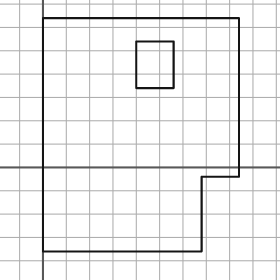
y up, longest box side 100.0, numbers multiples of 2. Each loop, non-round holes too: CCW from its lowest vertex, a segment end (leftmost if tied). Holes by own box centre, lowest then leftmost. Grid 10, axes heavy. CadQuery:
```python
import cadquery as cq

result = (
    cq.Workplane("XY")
    .moveTo(0.0, -36.0)
    .lineTo(68.0, -36.0)
    .lineTo(68.0, -4.0)
    .lineTo(84.0, -4.0)
    .lineTo(84.0, 64.0)
    .lineTo(0.0, 64.0)
    .close()
    .moveTo(40.0, 34.0)
    .lineTo(56.0, 34.0)
    .lineTo(56.0, 54.0)
    .lineTo(40.0, 54.0)
    .close()
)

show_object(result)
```